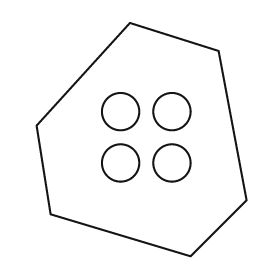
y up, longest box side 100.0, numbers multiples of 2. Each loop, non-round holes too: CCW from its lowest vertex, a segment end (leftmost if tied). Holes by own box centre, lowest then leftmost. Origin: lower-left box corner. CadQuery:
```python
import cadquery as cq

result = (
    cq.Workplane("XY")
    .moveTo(66.0, 0.0)
    .lineTo(90.0, 24.0)
    .lineTo(78.0, 88.0)
    .lineTo(40.0, 100.0)
    .lineTo(0.0, 56.0)
    .lineTo(6.0, 18.0)
    .close()
    .moveTo(36.0, 40.0)
    .circle(8.0)
    .moveTo(58.0, 40.0)
    .circle(8.0)
    .moveTo(36.0, 62.0)
    .circle(8.0)
    .moveTo(58.0, 62.0)
    .circle(8.0)
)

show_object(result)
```